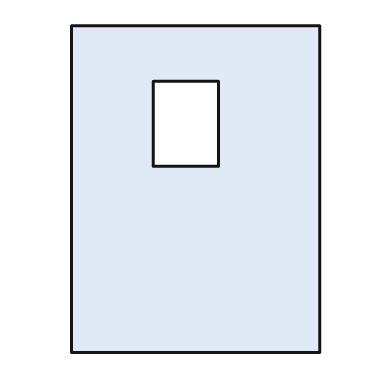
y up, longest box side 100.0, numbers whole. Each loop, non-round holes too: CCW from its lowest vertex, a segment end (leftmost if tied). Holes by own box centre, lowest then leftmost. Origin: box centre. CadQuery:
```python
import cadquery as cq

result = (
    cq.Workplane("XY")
    .moveTo(-38.0, -50.0)
    .lineTo(38.0, -50.0)
    .lineTo(38.0, 50.0)
    .lineTo(-38.0, 50.0)
    .close()
    .moveTo(-13.0, 7.0)
    .lineTo(7.0, 7.0)
    .lineTo(7.0, 33.0)
    .lineTo(-13.0, 33.0)
    .close()
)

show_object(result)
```